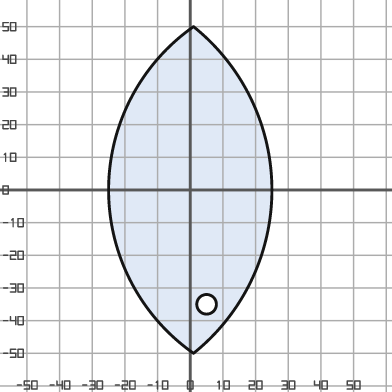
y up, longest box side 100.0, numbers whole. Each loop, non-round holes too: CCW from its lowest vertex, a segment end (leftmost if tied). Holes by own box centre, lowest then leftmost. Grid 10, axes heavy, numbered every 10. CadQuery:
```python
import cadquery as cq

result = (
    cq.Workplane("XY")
    .moveTo(1.0, -50.0)
    .threePointArc((25.0, 0.0), (1.0, 50.0))
    .threePointArc((-25.0, 0.0), (1.0, -50.0))
    .close()
    .moveTo(5.0, -35.0)
    .circle(3.0)
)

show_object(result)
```